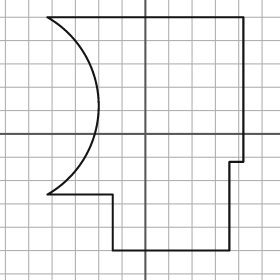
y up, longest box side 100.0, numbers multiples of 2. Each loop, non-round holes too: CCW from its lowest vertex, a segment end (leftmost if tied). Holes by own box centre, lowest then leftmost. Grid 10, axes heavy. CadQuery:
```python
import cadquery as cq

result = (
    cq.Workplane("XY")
    .moveTo(-14.0, -50.0)
    .lineTo(36.0, -50.0)
    .lineTo(36.0, -12.0)
    .lineTo(42.0, -12.0)
    .lineTo(42.0, 50.0)
    .lineTo(-42.0, 50.0)
    .threePointArc((-20.0, 12.0), (-42.0, -26.0))
    .lineTo(-14.0, -26.0)
    .close()
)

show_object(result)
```